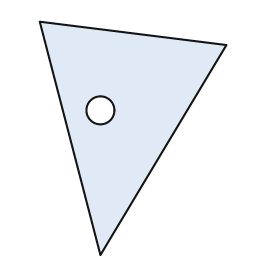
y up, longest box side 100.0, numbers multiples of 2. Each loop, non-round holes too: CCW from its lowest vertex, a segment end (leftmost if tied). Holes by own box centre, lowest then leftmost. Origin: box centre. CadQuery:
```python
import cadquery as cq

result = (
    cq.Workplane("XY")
    .moveTo(-14.0, -50.0)
    .lineTo(40.0, 40.0)
    .lineTo(-40.0, 50.0)
    .close()
    .moveTo(-14.0, 12.0)
    .circle(6.0)
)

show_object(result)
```